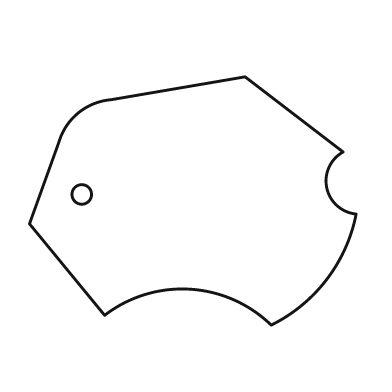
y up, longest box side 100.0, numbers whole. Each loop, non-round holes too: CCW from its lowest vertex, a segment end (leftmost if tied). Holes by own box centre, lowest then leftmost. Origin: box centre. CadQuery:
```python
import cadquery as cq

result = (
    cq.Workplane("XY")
    .moveTo(24.0, -38.0)
    .threePointArc((41.0, -24.0), (50.0, -4.0))
    .threePointArc((41.0, 4.0), (46.0, 15.0))
    .lineTo(16.0, 38.0)
    .lineTo(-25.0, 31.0)
    .threePointArc((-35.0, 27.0), (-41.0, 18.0))
    .lineTo(-50.0, -7.0)
    .lineTo(-27.0, -35.0)
    .threePointArc((-1.0, -27.0), (24.0, -38.0))
    .close()
    .moveTo(-34.0, 2.0)
    .circle(3.0)
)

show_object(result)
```